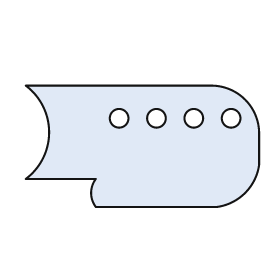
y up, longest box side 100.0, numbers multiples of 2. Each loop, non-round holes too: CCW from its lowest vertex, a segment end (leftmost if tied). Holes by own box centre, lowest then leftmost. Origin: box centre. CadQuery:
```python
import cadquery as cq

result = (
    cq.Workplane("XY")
    .moveTo(-20.0, -26.0)
    .lineTo(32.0, -26.0)
    .threePointArc((44.0, -20.0), (50.0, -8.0))
    .lineTo(50.0, 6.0)
    .threePointArc((44.0, 20.0), (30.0, 26.0))
    .lineTo(-50.0, 26.0)
    .threePointArc((-40.0, 6.0), (-50.0, -14.0))
    .lineTo(-20.0, -14.0)
    .threePointArc((-22.0, -20.0), (-20.0, -26.0))
    .close()
    .moveTo(-10.0, 12.0)
    .circle(4.0)
    .moveTo(6.0, 12.0)
    .circle(4.0)
    .moveTo(22.0, 12.0)
    .circle(4.0)
    .moveTo(38.0, 12.0)
    .circle(4.0)
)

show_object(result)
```